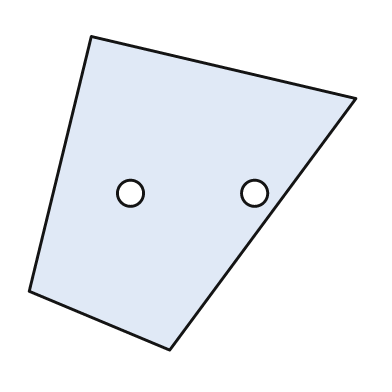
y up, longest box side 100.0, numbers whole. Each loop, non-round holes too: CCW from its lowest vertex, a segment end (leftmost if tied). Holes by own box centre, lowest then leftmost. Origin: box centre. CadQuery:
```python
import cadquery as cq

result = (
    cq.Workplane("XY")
    .moveTo(-7.0, -48.0)
    .lineTo(50.0, 29.0)
    .lineTo(-31.0, 48.0)
    .lineTo(-50.0, -30.0)
    .close()
    .moveTo(-19.0, 0.0)
    .circle(4.0)
    .moveTo(19.0, 0.0)
    .circle(4.0)
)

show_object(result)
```